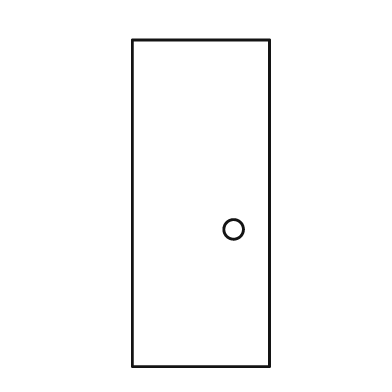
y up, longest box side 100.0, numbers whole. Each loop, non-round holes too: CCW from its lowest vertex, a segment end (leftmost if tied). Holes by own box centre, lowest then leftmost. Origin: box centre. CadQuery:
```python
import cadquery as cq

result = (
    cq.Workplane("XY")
    .moveTo(-21.0, -50.0)
    .lineTo(21.0, -50.0)
    .lineTo(21.0, 50.0)
    .lineTo(-21.0, 50.0)
    .close()
    .moveTo(10.0, -8.0)
    .circle(3.0)
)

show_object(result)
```